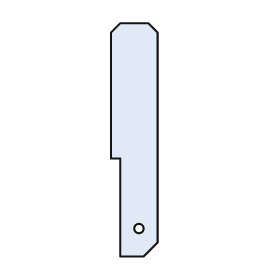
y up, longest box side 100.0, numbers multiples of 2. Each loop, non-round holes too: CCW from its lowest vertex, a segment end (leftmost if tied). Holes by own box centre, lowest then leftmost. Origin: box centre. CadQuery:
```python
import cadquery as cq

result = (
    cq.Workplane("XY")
    .moveTo(-6.0, -50.0)
    .lineTo(4.0, -50.0)
    .lineTo(10.0, -44.0)
    .lineTo(10.0, 46.0)
    .lineTo(6.0, 50.0)
    .lineTo(-6.0, 50.0)
    .lineTo(-10.0, 46.0)
    .lineTo(-10.0, -8.0)
    .lineTo(-6.0, -8.0)
    .close()
    .moveTo(2.0, -38.0)
    .circle(2.0)
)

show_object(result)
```